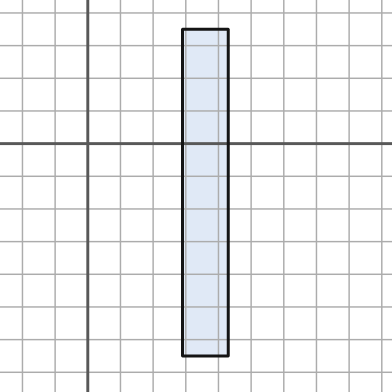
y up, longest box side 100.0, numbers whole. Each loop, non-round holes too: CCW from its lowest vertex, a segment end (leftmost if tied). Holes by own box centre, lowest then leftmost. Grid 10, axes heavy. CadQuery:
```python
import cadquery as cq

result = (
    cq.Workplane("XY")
    .moveTo(29.0, -65.0)
    .lineTo(43.0, -65.0)
    .lineTo(43.0, 35.0)
    .lineTo(29.0, 35.0)
    .close()
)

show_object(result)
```